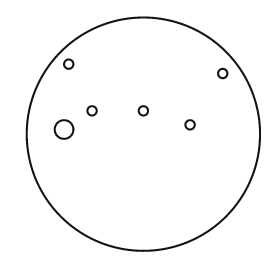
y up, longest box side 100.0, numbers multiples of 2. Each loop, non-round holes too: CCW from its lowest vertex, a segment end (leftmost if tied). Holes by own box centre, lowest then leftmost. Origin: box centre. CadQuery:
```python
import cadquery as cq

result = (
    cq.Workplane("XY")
    .moveTo(0.0, 0.0)
    .circle(50.0)
    .moveTo(-34.0, 2.0)
    .circle(4.0)
    .moveTo(20.0, 4.0)
    .circle(2.0)
    .moveTo(-22.0, 10.0)
    .circle(2.0)
    .moveTo(0.0, 10.0)
    .circle(2.0)
    .moveTo(34.0, 26.0)
    .circle(2.0)
    .moveTo(-32.0, 30.0)
    .circle(2.0)
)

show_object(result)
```